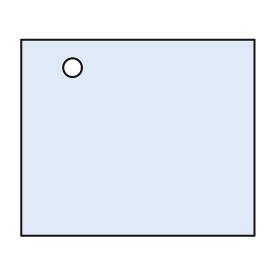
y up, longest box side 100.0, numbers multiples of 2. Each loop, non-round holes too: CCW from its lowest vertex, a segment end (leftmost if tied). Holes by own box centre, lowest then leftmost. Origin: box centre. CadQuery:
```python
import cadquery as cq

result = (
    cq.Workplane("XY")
    .moveTo(-50.0, -42.0)
    .lineTo(50.0, -42.0)
    .lineTo(50.0, 42.0)
    .lineTo(-50.0, 42.0)
    .close()
    .moveTo(-28.0, 30.0)
    .circle(4.0)
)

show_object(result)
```